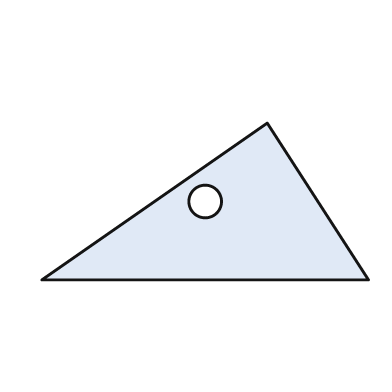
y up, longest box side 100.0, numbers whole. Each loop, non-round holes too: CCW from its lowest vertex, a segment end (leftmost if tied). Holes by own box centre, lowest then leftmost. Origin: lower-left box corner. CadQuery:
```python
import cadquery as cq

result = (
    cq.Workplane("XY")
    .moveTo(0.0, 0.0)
    .lineTo(100.0, 0.0)
    .lineTo(69.0, 48.0)
    .close()
    .moveTo(50.0, 24.0)
    .circle(5.0)
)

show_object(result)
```